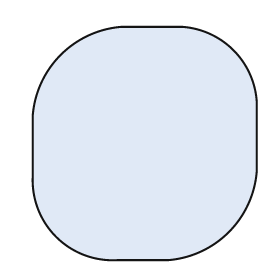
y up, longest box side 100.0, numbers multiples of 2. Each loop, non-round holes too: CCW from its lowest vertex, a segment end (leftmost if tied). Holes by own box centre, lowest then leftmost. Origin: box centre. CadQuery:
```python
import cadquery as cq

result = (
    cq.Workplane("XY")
    .moveTo(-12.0, -50.0)
    .lineTo(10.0, -50.0)
    .threePointArc((36.0, -38.0), (48.0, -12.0))
    .lineTo(48.0, 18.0)
    .threePointArc((38.0, 40.0), (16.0, 50.0))
    .lineTo(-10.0, 50.0)
    .threePointArc((-36.0, 38.0), (-48.0, 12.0))
    .lineTo(-48.0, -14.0)
    .threePointArc((-38.0, -40.0), (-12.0, -50.0))
    .close()
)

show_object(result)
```